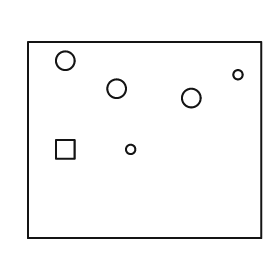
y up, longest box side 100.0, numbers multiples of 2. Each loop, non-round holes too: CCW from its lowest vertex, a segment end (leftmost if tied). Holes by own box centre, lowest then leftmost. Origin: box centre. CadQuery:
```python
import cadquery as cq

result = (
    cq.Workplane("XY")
    .moveTo(-50.0, -42.0)
    .lineTo(50.0, -42.0)
    .lineTo(50.0, 42.0)
    .lineTo(-50.0, 42.0)
    .close()
    .moveTo(-38.0, -8.0)
    .lineTo(-30.0, -8.0)
    .lineTo(-30.0, 0.0)
    .lineTo(-38.0, 0.0)
    .close()
    .moveTo(-6.0, -4.0)
    .circle(2.0)
    .moveTo(20.0, 18.0)
    .circle(4.0)
    .moveTo(-12.0, 22.0)
    .circle(4.0)
    .moveTo(40.0, 28.0)
    .circle(2.0)
    .moveTo(-34.0, 34.0)
    .circle(4.0)
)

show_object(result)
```